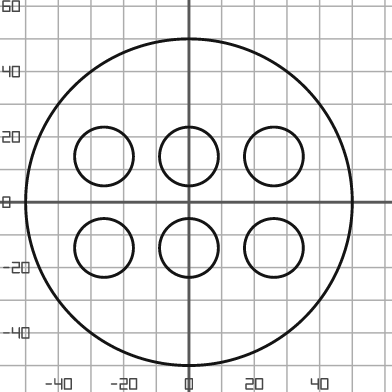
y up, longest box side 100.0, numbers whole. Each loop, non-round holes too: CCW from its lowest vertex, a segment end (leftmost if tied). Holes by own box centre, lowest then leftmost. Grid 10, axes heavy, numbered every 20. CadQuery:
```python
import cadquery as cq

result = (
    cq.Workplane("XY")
    .moveTo(0.0, 0.0)
    .circle(50.0)
    .moveTo(-26.0, -14.0)
    .circle(9.0)
    .moveTo(0.0, -14.0)
    .circle(9.0)
    .moveTo(26.0, -14.0)
    .circle(9.0)
    .moveTo(-26.0, 14.0)
    .circle(9.0)
    .moveTo(0.0, 14.0)
    .circle(9.0)
    .moveTo(26.0, 14.0)
    .circle(9.0)
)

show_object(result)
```